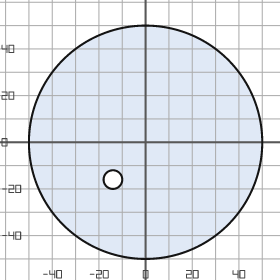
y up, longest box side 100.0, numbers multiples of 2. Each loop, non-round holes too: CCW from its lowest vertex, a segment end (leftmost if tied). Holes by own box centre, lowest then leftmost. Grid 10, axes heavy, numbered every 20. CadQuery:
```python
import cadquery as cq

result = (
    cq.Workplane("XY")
    .moveTo(0.0, 0.0)
    .circle(50.0)
    .moveTo(-14.0, -16.0)
    .circle(4.0)
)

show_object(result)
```